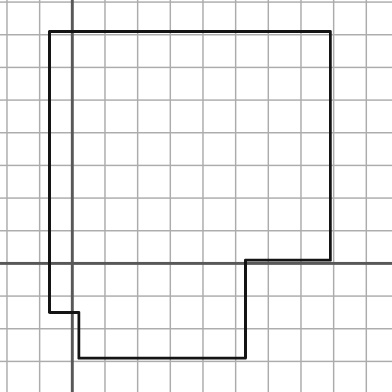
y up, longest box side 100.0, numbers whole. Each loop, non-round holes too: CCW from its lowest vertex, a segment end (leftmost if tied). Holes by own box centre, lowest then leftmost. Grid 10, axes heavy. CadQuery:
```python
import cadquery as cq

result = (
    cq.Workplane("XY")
    .moveTo(2.0, -29.0)
    .lineTo(53.0, -29.0)
    .lineTo(53.0, 1.0)
    .lineTo(79.0, 1.0)
    .lineTo(79.0, 71.0)
    .lineTo(-7.0, 71.0)
    .lineTo(-7.0, -15.0)
    .lineTo(2.0, -15.0)
    .close()
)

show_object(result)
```